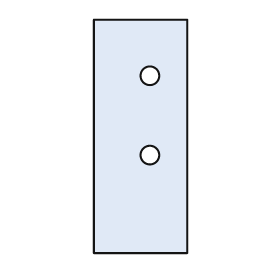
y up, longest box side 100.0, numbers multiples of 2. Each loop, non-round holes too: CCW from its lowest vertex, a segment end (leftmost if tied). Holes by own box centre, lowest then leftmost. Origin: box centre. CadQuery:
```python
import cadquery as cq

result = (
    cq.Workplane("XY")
    .moveTo(-20.0, -50.0)
    .lineTo(20.0, -50.0)
    .lineTo(20.0, 50.0)
    .lineTo(-20.0, 50.0)
    .close()
    .moveTo(4.0, -8.0)
    .circle(4.0)
    .moveTo(4.0, 26.0)
    .circle(4.0)
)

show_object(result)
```